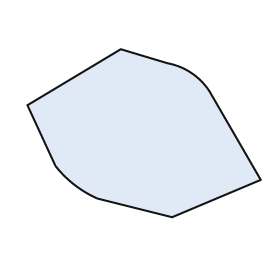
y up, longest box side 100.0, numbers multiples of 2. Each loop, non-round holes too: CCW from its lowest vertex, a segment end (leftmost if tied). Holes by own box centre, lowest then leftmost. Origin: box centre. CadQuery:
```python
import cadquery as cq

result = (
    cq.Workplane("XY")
    .moveTo(12.0, -36.0)
    .lineTo(50.0, -20.0)
    .lineTo(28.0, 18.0)
    .threePointArc((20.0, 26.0), (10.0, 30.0))
    .lineTo(-10.0, 36.0)
    .lineTo(-50.0, 12.0)
    .lineTo(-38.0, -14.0)
    .threePointArc((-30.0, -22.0), (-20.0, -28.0))
    .close()
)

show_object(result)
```